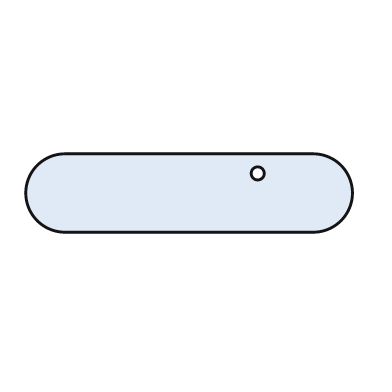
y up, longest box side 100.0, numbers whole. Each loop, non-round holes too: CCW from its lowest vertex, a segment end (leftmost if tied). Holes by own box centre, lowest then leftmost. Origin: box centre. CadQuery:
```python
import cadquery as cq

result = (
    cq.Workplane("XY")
    .moveTo(-38.0, -12.0)
    .lineTo(38.0, -12.0)
    .threePointArc((50.0, 0.0), (38.0, 12.0))
    .lineTo(-38.0, 12.0)
    .threePointArc((-50.0, 0.0), (-38.0, -12.0))
    .close()
    .moveTo(21.0, 6.0)
    .circle(2.0)
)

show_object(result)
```